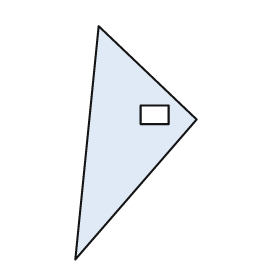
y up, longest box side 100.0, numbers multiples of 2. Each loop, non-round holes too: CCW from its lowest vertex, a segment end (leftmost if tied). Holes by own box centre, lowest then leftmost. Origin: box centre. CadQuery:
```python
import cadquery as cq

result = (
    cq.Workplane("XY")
    .moveTo(-26.0, -50.0)
    .lineTo(26.0, 10.0)
    .lineTo(-16.0, 50.0)
    .close()
    .moveTo(2.0, 8.0)
    .lineTo(14.0, 8.0)
    .lineTo(14.0, 16.0)
    .lineTo(2.0, 16.0)
    .close()
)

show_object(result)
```